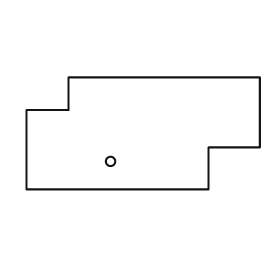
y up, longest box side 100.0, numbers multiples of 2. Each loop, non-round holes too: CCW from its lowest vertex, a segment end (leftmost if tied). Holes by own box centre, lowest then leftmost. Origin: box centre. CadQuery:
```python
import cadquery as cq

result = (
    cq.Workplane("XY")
    .moveTo(-50.0, -24.0)
    .lineTo(28.0, -24.0)
    .lineTo(28.0, -6.0)
    .lineTo(50.0, -6.0)
    .lineTo(50.0, 24.0)
    .lineTo(-32.0, 24.0)
    .lineTo(-32.0, 10.0)
    .lineTo(-50.0, 10.0)
    .close()
    .moveTo(-14.0, -12.0)
    .circle(2.0)
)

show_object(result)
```